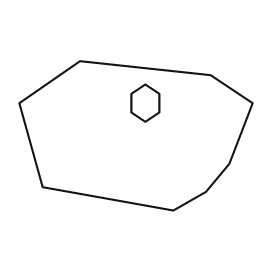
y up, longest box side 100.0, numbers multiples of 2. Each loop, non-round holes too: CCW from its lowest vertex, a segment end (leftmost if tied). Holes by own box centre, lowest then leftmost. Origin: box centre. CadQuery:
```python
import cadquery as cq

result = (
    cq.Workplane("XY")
    .moveTo(16.0, -32.0)
    .lineTo(30.0, -24.0)
    .lineTo(40.0, -12.0)
    .lineTo(50.0, 14.0)
    .lineTo(32.0, 26.0)
    .lineTo(-24.0, 32.0)
    .lineTo(-50.0, 14.0)
    .lineTo(-40.0, -22.0)
    .close()
    .moveTo(4.0, 6.0)
    .lineTo(10.0, 10.0)
    .lineTo(10.0, 18.0)
    .lineTo(4.0, 22.0)
    .lineTo(-2.0, 18.0)
    .lineTo(-2.0, 10.0)
    .close()
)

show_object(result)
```